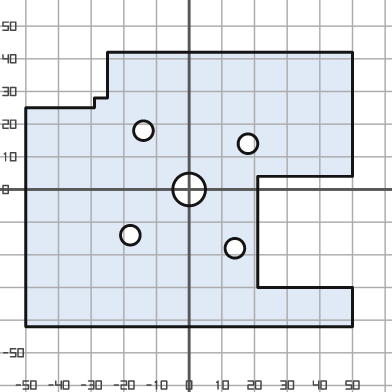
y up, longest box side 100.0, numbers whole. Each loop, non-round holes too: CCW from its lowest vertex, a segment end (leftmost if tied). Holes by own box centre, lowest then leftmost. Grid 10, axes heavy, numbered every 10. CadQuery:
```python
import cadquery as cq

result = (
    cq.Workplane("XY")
    .moveTo(-50.0, -42.0)
    .lineTo(50.0, -42.0)
    .lineTo(50.0, -30.0)
    .lineTo(21.0, -30.0)
    .lineTo(21.0, 4.0)
    .lineTo(50.0, 4.0)
    .lineTo(50.0, 42.0)
    .lineTo(-25.0, 42.0)
    .lineTo(-25.0, 28.0)
    .lineTo(-29.0, 28.0)
    .lineTo(-29.0, 25.0)
    .lineTo(-50.0, 25.0)
    .close()
    .moveTo(14.0, -18.0)
    .circle(3.0)
    .moveTo(-18.0, -14.0)
    .circle(3.0)
    .moveTo(0.0, 0.0)
    .circle(5.0)
    .moveTo(18.0, 14.0)
    .circle(3.0)
    .moveTo(-14.0, 18.0)
    .circle(3.0)
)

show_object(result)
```